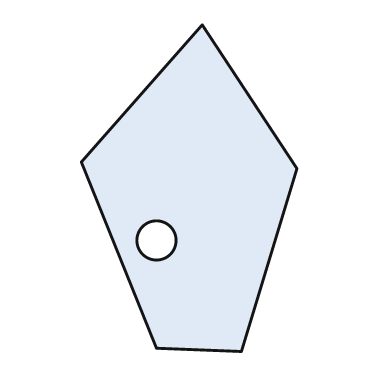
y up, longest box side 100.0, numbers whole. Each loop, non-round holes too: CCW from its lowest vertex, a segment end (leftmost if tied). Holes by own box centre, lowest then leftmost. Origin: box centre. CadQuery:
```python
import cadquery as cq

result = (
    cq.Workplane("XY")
    .moveTo(16.0, -50.0)
    .lineTo(33.0, 6.0)
    .lineTo(4.0, 50.0)
    .lineTo(-33.0, 8.0)
    .lineTo(-10.0, -49.0)
    .close()
    .moveTo(-10.0, -16.0)
    .circle(6.0)
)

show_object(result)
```